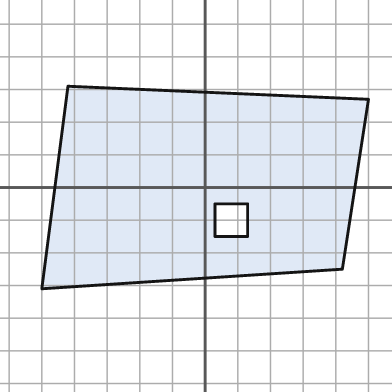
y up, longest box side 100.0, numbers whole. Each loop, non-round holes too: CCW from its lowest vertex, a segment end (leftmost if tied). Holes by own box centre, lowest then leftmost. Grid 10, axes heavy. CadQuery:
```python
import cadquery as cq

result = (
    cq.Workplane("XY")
    .moveTo(-50.0, -31.0)
    .lineTo(42.0, -25.0)
    .lineTo(50.0, 27.0)
    .lineTo(-42.0, 31.0)
    .close()
    .moveTo(3.0, -15.0)
    .lineTo(13.0, -15.0)
    .lineTo(13.0, -5.0)
    .lineTo(3.0, -5.0)
    .close()
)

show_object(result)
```